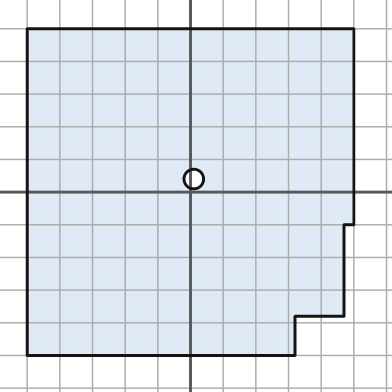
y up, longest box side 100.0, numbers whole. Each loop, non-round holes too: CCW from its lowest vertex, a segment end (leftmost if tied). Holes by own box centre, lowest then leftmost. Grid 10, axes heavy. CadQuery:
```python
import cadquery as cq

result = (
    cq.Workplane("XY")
    .moveTo(-50.0, -50.0)
    .lineTo(32.0, -50.0)
    .lineTo(32.0, -38.0)
    .lineTo(47.0, -38.0)
    .lineTo(47.0, -10.0)
    .lineTo(50.0, -10.0)
    .lineTo(50.0, 50.0)
    .lineTo(-50.0, 50.0)
    .close()
    .moveTo(1.0, 4.0)
    .circle(3.0)
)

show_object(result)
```